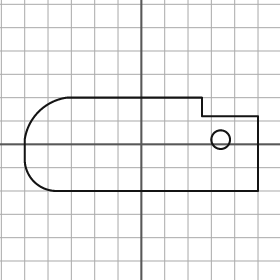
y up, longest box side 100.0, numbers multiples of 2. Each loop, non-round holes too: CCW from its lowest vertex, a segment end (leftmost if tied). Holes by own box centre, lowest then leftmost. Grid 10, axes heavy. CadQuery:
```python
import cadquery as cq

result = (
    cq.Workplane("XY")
    .moveTo(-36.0, -20.0)
    .lineTo(50.0, -20.0)
    .lineTo(50.0, 12.0)
    .lineTo(26.0, 12.0)
    .lineTo(26.0, 20.0)
    .lineTo(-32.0, 20.0)
    .threePointArc((-44.0, 14.0), (-50.0, 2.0))
    .lineTo(-50.0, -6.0)
    .threePointArc((-46.0, -16.0), (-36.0, -20.0))
    .close()
    .moveTo(34.0, 2.0)
    .circle(4.0)
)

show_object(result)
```